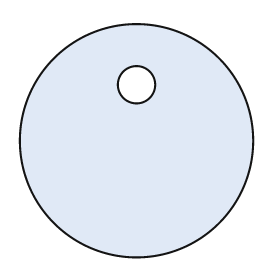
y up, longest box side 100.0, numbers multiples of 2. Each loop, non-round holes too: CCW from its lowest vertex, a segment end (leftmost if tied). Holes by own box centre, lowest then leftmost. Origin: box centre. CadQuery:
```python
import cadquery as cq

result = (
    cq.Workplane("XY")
    .moveTo(0.0, 0.0)
    .circle(50.0)
    .moveTo(0.0, 24.0)
    .circle(8.0)
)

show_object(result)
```